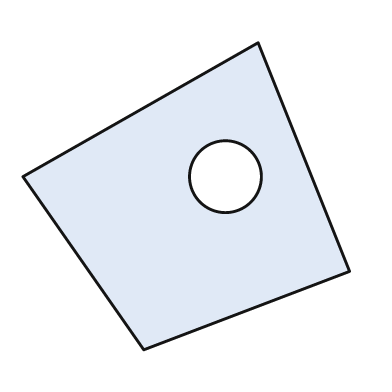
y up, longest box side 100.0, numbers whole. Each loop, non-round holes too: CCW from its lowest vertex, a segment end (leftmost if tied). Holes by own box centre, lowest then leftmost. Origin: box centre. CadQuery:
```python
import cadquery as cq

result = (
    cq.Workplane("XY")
    .moveTo(-13.0, -47.0)
    .lineTo(50.0, -23.0)
    .lineTo(22.0, 47.0)
    .lineTo(-50.0, 6.0)
    .close()
    .moveTo(12.0, 6.0)
    .circle(11.0)
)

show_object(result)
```